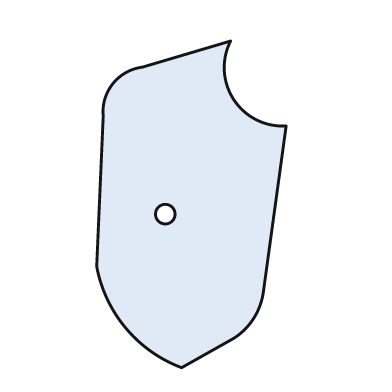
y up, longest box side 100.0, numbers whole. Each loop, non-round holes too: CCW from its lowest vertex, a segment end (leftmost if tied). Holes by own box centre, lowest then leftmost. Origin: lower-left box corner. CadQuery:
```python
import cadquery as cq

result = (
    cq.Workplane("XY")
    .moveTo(26.0, 0.0)
    .lineTo(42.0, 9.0)
    .threePointArc((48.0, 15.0), (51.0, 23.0))
    .lineTo(58.0, 74.0)
    .threePointArc((42.0, 82.0), (41.0, 100.0))
    .lineTo(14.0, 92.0)
    .threePointArc((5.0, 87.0), (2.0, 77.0))
    .lineTo(0.0, 31.0)
    .threePointArc((9.0, 12.0), (26.0, 0.0))
    .close()
    .moveTo(21.0, 47.0)
    .circle(3.0)
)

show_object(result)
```